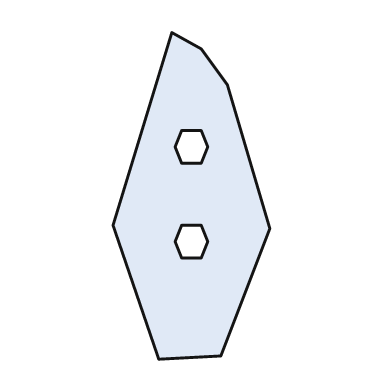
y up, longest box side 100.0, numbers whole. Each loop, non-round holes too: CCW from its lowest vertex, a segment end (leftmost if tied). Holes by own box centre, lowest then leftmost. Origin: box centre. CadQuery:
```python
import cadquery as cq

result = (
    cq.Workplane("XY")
    .moveTo(-10.0, -50.0)
    .lineTo(9.0, -49.0)
    .lineTo(24.0, -10.0)
    .lineTo(11.0, 34.0)
    .lineTo(3.0, 45.0)
    .lineTo(-6.0, 50.0)
    .lineTo(-24.0, -9.0)
    .close()
    .moveTo(-3.0, -19.0)
    .lineTo(3.0, -19.0)
    .lineTo(5.0, -14.0)
    .lineTo(3.0, -9.0)
    .lineTo(-3.0, -9.0)
    .lineTo(-5.0, -14.0)
    .close()
    .moveTo(-3.0, 10.0)
    .lineTo(3.0, 10.0)
    .lineTo(5.0, 15.0)
    .lineTo(3.0, 20.0)
    .lineTo(-3.0, 20.0)
    .lineTo(-5.0, 15.0)
    .close()
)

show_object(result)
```